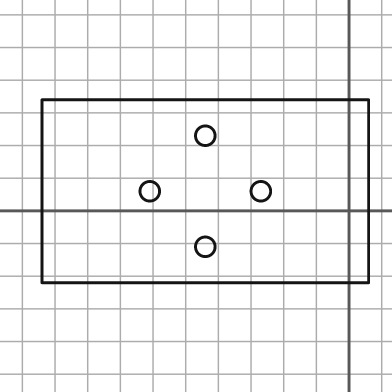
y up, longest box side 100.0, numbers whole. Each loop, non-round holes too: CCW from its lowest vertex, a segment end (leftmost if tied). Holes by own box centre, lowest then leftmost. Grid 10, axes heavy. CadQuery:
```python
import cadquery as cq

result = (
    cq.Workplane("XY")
    .moveTo(-94.0, -22.0)
    .lineTo(6.0, -22.0)
    .lineTo(6.0, 34.0)
    .lineTo(-94.0, 34.0)
    .close()
    .moveTo(-44.0, -11.0)
    .circle(3.0)
    .moveTo(-61.0, 6.0)
    .circle(3.0)
    .moveTo(-27.0, 6.0)
    .circle(3.0)
    .moveTo(-44.0, 23.0)
    .circle(3.0)
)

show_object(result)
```